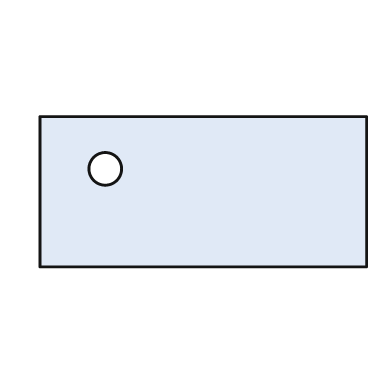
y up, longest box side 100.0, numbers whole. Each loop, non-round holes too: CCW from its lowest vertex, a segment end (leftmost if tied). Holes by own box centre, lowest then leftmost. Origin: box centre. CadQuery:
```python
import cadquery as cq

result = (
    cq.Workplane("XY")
    .moveTo(-50.0, -23.0)
    .lineTo(50.0, -23.0)
    .lineTo(50.0, 23.0)
    .lineTo(-50.0, 23.0)
    .close()
    .moveTo(-30.0, 7.0)
    .circle(5.0)
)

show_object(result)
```